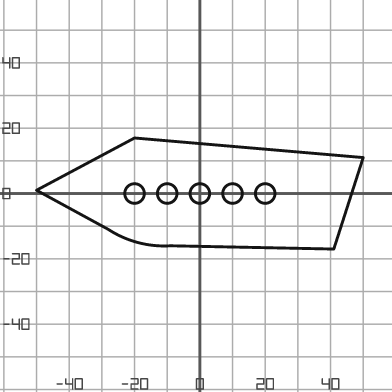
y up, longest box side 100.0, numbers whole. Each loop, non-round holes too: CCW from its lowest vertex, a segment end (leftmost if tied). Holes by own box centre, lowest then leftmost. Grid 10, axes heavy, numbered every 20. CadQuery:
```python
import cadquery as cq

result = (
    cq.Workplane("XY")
    .moveTo(41.0, -17.0)
    .lineTo(50.0, 11.0)
    .lineTo(-20.0, 17.0)
    .lineTo(-50.0, 1.0)
    .lineTo(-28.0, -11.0)
    .threePointArc((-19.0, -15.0), (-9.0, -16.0))
    .close()
    .moveTo(-20.0, 0.0)
    .circle(3.0)
    .moveTo(-10.0, 0.0)
    .circle(3.0)
    .moveTo(0.0, 0.0)
    .circle(3.0)
    .moveTo(10.0, 0.0)
    .circle(3.0)
    .moveTo(20.0, 0.0)
    .circle(3.0)
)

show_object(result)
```